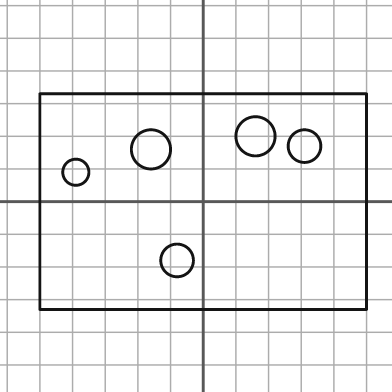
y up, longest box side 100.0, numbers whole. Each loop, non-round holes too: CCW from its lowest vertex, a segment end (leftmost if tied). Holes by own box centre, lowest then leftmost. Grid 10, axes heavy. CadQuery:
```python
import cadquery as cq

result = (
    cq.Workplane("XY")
    .moveTo(-50.0, -33.0)
    .lineTo(50.0, -33.0)
    .lineTo(50.0, 33.0)
    .lineTo(-50.0, 33.0)
    .close()
    .moveTo(-8.0, -18.0)
    .circle(5.0)
    .moveTo(-39.0, 9.0)
    .circle(4.0)
    .moveTo(-16.0, 16.0)
    .circle(6.0)
    .moveTo(31.0, 17.0)
    .circle(5.0)
    .moveTo(16.0, 20.0)
    .circle(6.0)
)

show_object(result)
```